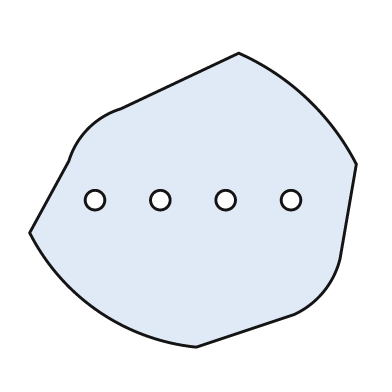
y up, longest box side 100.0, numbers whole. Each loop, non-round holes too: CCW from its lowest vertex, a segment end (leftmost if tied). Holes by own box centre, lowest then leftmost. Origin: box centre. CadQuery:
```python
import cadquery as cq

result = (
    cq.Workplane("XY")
    .moveTo(1.0, -45.0)
    .lineTo(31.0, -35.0)
    .threePointArc((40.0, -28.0), (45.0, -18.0))
    .lineTo(50.0, 11.0)
    .threePointArc((35.0, 31.0), (14.0, 45.0))
    .lineTo(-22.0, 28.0)
    .threePointArc((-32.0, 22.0), (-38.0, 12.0))
    .lineTo(-50.0, -10.0)
    .threePointArc((-29.0, -34.0), (1.0, -45.0))
    .close()
    .moveTo(-30.0, 0.0)
    .circle(3.0)
    .moveTo(-10.0, 0.0)
    .circle(3.0)
    .moveTo(10.0, 0.0)
    .circle(3.0)
    .moveTo(30.0, 0.0)
    .circle(3.0)
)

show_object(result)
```